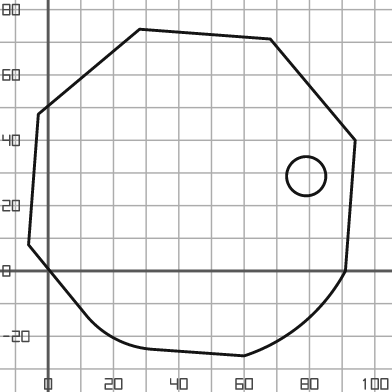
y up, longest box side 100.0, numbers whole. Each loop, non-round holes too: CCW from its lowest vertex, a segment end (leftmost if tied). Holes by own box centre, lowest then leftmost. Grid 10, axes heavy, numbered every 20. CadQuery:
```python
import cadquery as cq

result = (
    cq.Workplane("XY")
    .moveTo(60.0, -26.0)
    .threePointArc((78.0, -16.0), (91.0, 0.0))
    .lineTo(94.0, 40.0)
    .lineTo(68.0, 71.0)
    .lineTo(28.0, 74.0)
    .lineTo(-3.0, 48.0)
    .lineTo(-6.0, 8.0)
    .lineTo(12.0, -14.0)
    .threePointArc((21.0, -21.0), (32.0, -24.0))
    .close()
    .moveTo(79.0, 29.0)
    .circle(6.0)
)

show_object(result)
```